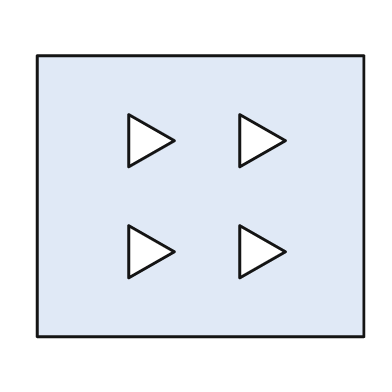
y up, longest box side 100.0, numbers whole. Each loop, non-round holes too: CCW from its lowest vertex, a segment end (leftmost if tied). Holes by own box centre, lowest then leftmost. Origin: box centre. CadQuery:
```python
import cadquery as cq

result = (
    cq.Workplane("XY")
    .moveTo(-50.0, -43.0)
    .lineTo(50.0, -43.0)
    .lineTo(50.0, 43.0)
    .lineTo(-50.0, 43.0)
    .close()
    .moveTo(-22.0, -25.0)
    .lineTo(-8.0, -17.0)
    .lineTo(-22.0, -9.0)
    .close()
    .moveTo(12.0, -25.0)
    .lineTo(26.0, -17.0)
    .lineTo(12.0, -9.0)
    .close()
    .moveTo(-22.0, 9.0)
    .lineTo(-8.0, 17.0)
    .lineTo(-22.0, 25.0)
    .close()
    .moveTo(12.0, 9.0)
    .lineTo(26.0, 17.0)
    .lineTo(12.0, 25.0)
    .close()
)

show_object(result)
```